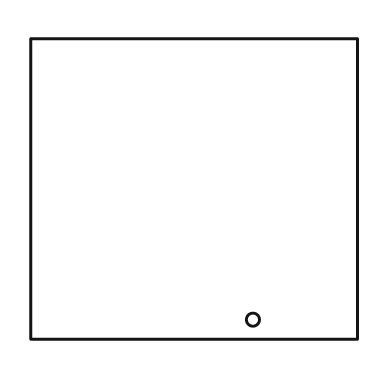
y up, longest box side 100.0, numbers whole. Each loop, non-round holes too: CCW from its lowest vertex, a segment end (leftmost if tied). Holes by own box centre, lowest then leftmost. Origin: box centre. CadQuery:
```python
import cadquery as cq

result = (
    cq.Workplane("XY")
    .moveTo(-50.0, -46.0)
    .lineTo(50.0, -46.0)
    .lineTo(50.0, 46.0)
    .lineTo(-50.0, 46.0)
    .close()
    .moveTo(18.0, -40.0)
    .circle(2.0)
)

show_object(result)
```